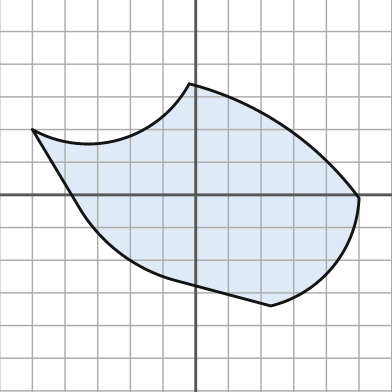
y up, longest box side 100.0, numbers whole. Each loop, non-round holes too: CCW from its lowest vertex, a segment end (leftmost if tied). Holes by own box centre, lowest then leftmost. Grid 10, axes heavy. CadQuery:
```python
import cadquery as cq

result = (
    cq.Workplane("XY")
    .moveTo(23.0, -34.0)
    .threePointArc((42.0, -22.0), (50.0, -1.0))
    .threePointArc((27.0, 21.0), (-2.0, 34.0))
    .threePointArc((-23.0, 17.0), (-50.0, 20.0))
    .lineTo(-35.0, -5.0)
    .threePointArc((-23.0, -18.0), (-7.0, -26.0))
    .close()
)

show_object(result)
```